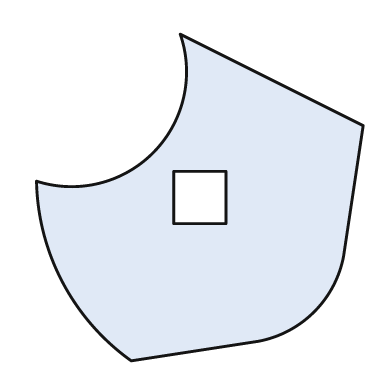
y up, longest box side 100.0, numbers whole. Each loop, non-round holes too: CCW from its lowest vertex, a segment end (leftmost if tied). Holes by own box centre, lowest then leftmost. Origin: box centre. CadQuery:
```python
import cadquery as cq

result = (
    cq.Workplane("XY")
    .moveTo(-21.0, -50.0)
    .lineTo(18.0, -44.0)
    .threePointArc((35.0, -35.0), (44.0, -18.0))
    .lineTo(50.0, 22.0)
    .lineTo(-6.0, 50.0)
    .threePointArc((-14.0, 14.0), (-50.0, 5.0))
    .threePointArc((-42.0, -26.0), (-21.0, -50.0))
    .close()
    .moveTo(-8.0, -8.0)
    .lineTo(8.0, -8.0)
    .lineTo(8.0, 8.0)
    .lineTo(-8.0, 8.0)
    .close()
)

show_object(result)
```